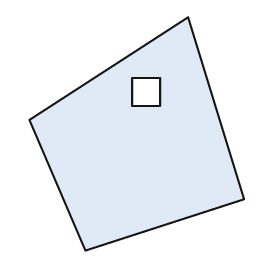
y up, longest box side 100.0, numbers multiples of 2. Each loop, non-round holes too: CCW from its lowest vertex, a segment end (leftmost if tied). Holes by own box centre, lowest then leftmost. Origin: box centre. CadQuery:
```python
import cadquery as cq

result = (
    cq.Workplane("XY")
    .moveTo(-22.0, -50.0)
    .lineTo(46.0, -28.0)
    .lineTo(22.0, 50.0)
    .lineTo(-46.0, 6.0)
    .close()
    .moveTo(-2.0, 12.0)
    .lineTo(10.0, 12.0)
    .lineTo(10.0, 24.0)
    .lineTo(-2.0, 24.0)
    .close()
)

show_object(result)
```